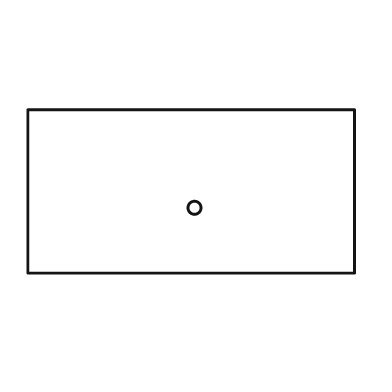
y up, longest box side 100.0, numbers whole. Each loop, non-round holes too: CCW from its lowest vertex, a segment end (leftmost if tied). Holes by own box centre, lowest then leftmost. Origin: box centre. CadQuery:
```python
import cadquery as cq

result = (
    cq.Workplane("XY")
    .moveTo(-50.0, -25.0)
    .lineTo(50.0, -25.0)
    .lineTo(50.0, 25.0)
    .lineTo(-50.0, 25.0)
    .close()
    .moveTo(1.0, -5.0)
    .circle(2.0)
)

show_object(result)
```